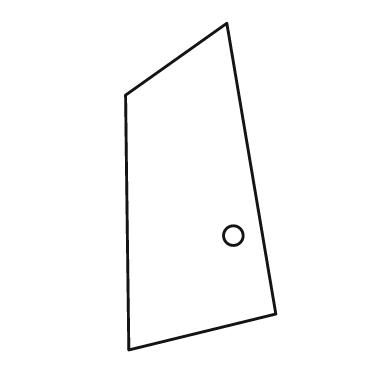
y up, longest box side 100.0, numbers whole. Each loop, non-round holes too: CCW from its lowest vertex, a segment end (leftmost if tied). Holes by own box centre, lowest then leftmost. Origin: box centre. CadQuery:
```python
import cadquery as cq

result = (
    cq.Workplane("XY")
    .moveTo(-22.0, -50.0)
    .lineTo(23.0, -39.0)
    .lineTo(8.0, 50.0)
    .lineTo(-23.0, 28.0)
    .close()
    .moveTo(10.0, -15.0)
    .circle(3.0)
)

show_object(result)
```